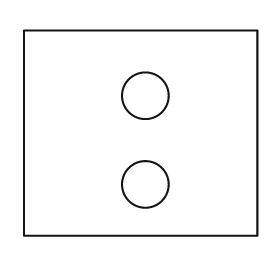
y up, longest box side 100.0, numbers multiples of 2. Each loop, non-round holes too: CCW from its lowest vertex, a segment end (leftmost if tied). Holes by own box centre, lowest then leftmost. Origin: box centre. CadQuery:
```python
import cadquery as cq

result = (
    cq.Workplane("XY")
    .moveTo(-50.0, -44.0)
    .lineTo(50.0, -44.0)
    .lineTo(50.0, 44.0)
    .lineTo(-50.0, 44.0)
    .close()
    .moveTo(2.0, -22.0)
    .circle(10.0)
    .moveTo(2.0, 16.0)
    .circle(10.0)
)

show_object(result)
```